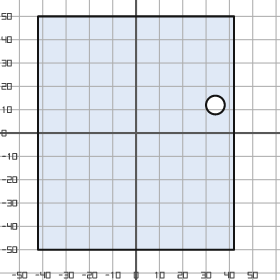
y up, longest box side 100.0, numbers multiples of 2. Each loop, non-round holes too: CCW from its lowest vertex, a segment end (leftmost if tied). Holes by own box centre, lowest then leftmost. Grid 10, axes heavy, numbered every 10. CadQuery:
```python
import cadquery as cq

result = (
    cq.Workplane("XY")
    .moveTo(-42.0, -50.0)
    .lineTo(42.0, -50.0)
    .lineTo(42.0, 50.0)
    .lineTo(-42.0, 50.0)
    .close()
    .moveTo(34.0, 12.0)
    .circle(4.0)
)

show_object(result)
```